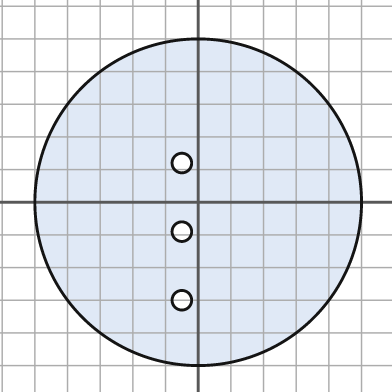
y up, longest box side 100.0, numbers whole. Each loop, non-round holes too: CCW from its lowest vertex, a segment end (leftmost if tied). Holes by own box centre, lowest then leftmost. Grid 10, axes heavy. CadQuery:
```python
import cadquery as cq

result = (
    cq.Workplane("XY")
    .moveTo(0.0, 0.0)
    .circle(50.0)
    .moveTo(-5.0, -30.0)
    .circle(3.0)
    .moveTo(-5.0, -9.0)
    .circle(3.0)
    .moveTo(-5.0, 12.0)
    .circle(3.0)
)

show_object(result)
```